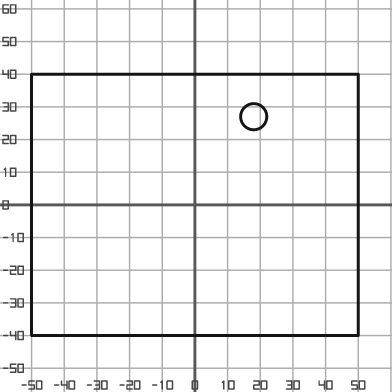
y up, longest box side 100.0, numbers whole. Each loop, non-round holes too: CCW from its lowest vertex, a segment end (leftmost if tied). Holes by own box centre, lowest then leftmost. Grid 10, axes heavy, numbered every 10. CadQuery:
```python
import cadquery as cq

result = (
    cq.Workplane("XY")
    .moveTo(-50.0, -40.0)
    .lineTo(50.0, -40.0)
    .lineTo(50.0, 40.0)
    .lineTo(-50.0, 40.0)
    .close()
    .moveTo(18.0, 27.0)
    .circle(4.0)
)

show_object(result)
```